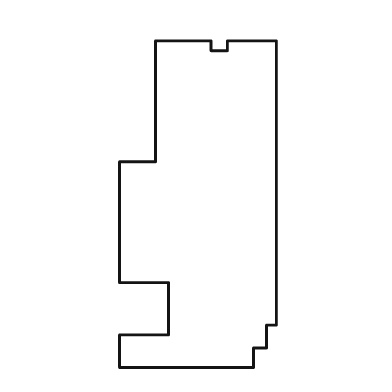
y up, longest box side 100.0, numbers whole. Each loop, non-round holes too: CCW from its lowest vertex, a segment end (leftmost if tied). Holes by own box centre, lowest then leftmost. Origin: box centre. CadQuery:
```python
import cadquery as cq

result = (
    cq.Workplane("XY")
    .moveTo(-24.0, -50.0)
    .lineTo(17.0, -50.0)
    .lineTo(17.0, -44.0)
    .lineTo(21.0, -44.0)
    .lineTo(21.0, -37.0)
    .lineTo(24.0, -37.0)
    .lineTo(24.0, 50.0)
    .lineTo(9.0, 50.0)
    .lineTo(9.0, 47.0)
    .lineTo(4.0, 47.0)
    .lineTo(4.0, 50.0)
    .lineTo(-13.0, 50.0)
    .lineTo(-13.0, 13.0)
    .lineTo(-24.0, 13.0)
    .lineTo(-24.0, -24.0)
    .lineTo(-9.0, -24.0)
    .lineTo(-9.0, -40.0)
    .lineTo(-24.0, -40.0)
    .close()
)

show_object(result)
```